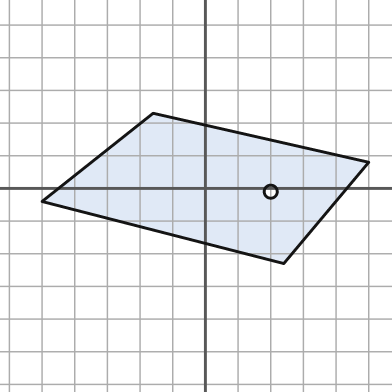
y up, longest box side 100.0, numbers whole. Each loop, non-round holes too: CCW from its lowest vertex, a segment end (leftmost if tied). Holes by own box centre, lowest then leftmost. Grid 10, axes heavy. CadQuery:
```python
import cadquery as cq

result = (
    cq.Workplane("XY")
    .moveTo(24.0, -23.0)
    .lineTo(50.0, 8.0)
    .lineTo(-16.0, 23.0)
    .lineTo(-50.0, -4.0)
    .close()
    .moveTo(20.0, -1.0)
    .circle(2.0)
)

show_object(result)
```